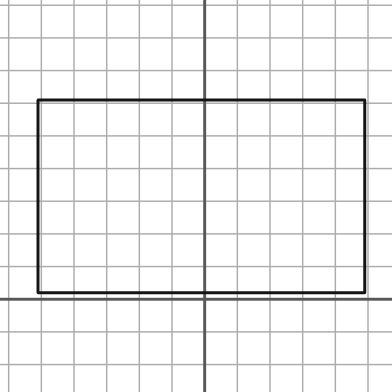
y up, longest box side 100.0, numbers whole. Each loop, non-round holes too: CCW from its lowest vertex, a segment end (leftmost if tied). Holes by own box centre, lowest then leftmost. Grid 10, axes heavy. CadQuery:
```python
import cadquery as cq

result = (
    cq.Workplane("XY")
    .moveTo(-51.0, 2.0)
    .lineTo(49.0, 2.0)
    .lineTo(49.0, 61.0)
    .lineTo(-51.0, 61.0)
    .close()
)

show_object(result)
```